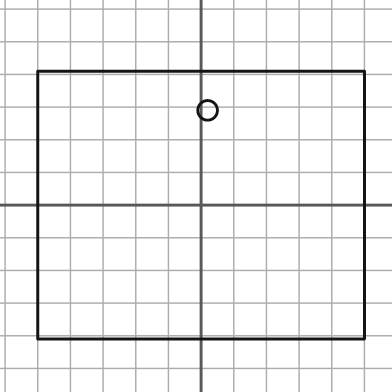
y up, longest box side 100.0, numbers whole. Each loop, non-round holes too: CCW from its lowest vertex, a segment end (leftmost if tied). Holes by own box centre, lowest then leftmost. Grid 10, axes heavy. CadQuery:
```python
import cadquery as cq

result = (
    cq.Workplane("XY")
    .moveTo(-50.0, -41.0)
    .lineTo(50.0, -41.0)
    .lineTo(50.0, 41.0)
    .lineTo(-50.0, 41.0)
    .close()
    .moveTo(2.0, 29.0)
    .circle(3.0)
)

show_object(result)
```